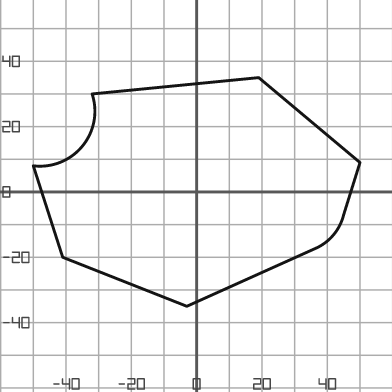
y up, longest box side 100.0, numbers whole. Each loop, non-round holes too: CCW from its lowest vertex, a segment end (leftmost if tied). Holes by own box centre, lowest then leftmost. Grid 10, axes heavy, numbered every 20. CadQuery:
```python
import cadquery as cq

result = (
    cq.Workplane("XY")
    .moveTo(-3.0, -35.0)
    .lineTo(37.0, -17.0)
    .threePointArc((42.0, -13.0), (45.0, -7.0))
    .lineTo(50.0, 9.0)
    .lineTo(19.0, 35.0)
    .lineTo(-32.0, 30.0)
    .threePointArc((-35.0, 14.0), (-50.0, 8.0))
    .lineTo(-41.0, -20.0)
    .close()
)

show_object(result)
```